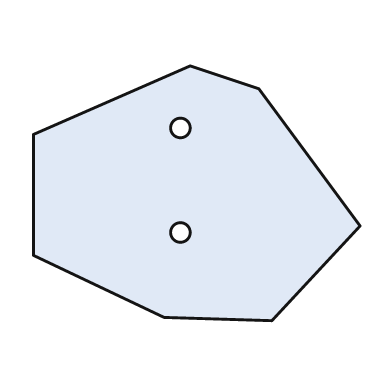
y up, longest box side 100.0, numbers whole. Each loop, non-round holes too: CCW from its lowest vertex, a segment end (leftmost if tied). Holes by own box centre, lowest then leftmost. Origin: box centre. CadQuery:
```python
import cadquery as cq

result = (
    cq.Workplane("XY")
    .moveTo(23.0, -39.0)
    .lineTo(50.0, -10.0)
    .lineTo(19.0, 32.0)
    .lineTo(-2.0, 39.0)
    .lineTo(-50.0, 18.0)
    .lineTo(-50.0, -19.0)
    .lineTo(-10.0, -38.0)
    .close()
    .moveTo(-5.0, -12.0)
    .circle(3.0)
    .moveTo(-5.0, 20.0)
    .circle(3.0)
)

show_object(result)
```